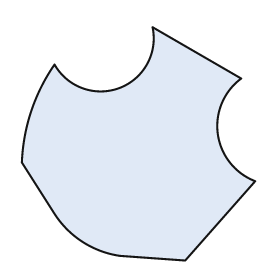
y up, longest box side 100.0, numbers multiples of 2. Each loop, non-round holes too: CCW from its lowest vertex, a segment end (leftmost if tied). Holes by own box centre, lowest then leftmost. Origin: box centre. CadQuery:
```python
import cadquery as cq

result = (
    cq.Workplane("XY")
    .moveTo(20.0, -50.0)
    .lineTo(50.0, -16.0)
    .threePointArc((34.0, 4.0), (44.0, 28.0))
    .lineTo(6.0, 50.0)
    .threePointArc((-8.0, 24.0), (-36.0, 34.0))
    .threePointArc((-46.0, 14.0), (-50.0, -8.0))
    .lineTo(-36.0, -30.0)
    .threePointArc((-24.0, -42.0), (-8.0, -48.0))
    .close()
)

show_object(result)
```